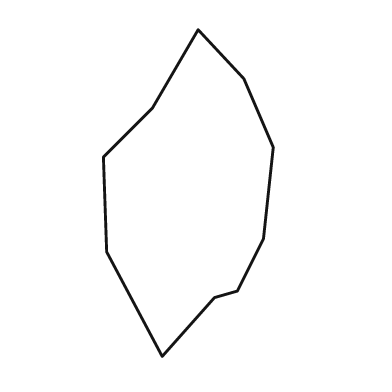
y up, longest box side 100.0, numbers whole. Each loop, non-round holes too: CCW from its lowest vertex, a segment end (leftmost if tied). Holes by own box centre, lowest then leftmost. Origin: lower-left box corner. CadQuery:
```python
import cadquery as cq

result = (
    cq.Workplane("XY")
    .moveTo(18.0, 0.0)
    .lineTo(34.0, 18.0)
    .lineTo(41.0, 20.0)
    .lineTo(49.0, 36.0)
    .lineTo(52.0, 64.0)
    .lineTo(43.0, 85.0)
    .lineTo(29.0, 100.0)
    .lineTo(15.0, 76.0)
    .lineTo(0.0, 61.0)
    .lineTo(1.0, 32.0)
    .close()
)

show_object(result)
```